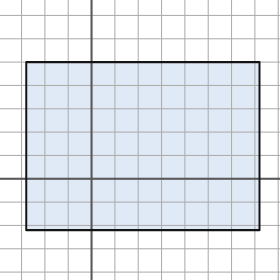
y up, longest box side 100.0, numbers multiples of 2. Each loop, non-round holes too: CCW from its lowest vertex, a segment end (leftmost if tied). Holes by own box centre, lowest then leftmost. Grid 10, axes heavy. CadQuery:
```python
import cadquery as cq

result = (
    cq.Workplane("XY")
    .moveTo(-28.0, -22.0)
    .lineTo(72.0, -22.0)
    .lineTo(72.0, 50.0)
    .lineTo(-28.0, 50.0)
    .close()
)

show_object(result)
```